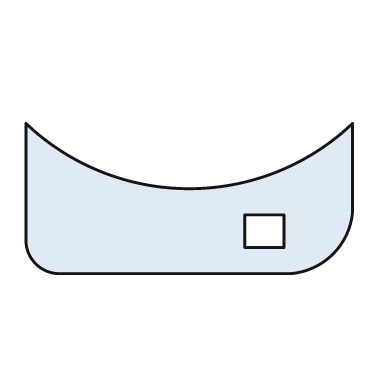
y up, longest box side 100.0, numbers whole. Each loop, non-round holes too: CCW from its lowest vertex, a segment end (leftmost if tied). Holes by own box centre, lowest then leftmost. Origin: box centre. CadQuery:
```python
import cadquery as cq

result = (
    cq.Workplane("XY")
    .moveTo(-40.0, -23.0)
    .lineTo(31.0, -23.0)
    .threePointArc((44.0, -17.0), (50.0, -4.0))
    .lineTo(50.0, 23.0)
    .threePointArc((0.0, 3.0), (-50.0, 23.0))
    .lineTo(-50.0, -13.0)
    .threePointArc((-47.0, -20.0), (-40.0, -23.0))
    .close()
    .moveTo(17.0, -15.0)
    .lineTo(29.0, -15.0)
    .lineTo(29.0, -5.0)
    .lineTo(17.0, -5.0)
    .close()
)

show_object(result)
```